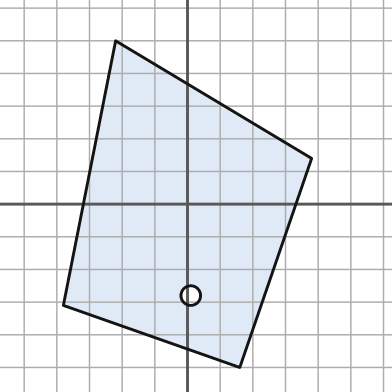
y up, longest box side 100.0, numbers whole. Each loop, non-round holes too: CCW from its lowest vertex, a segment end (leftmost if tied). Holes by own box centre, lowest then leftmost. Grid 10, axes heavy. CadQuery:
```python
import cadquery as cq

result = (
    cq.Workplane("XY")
    .moveTo(16.0, -50.0)
    .lineTo(38.0, 14.0)
    .lineTo(-22.0, 50.0)
    .lineTo(-38.0, -31.0)
    .close()
    .moveTo(1.0, -28.0)
    .circle(3.0)
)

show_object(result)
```